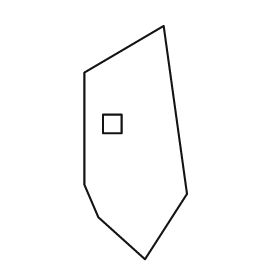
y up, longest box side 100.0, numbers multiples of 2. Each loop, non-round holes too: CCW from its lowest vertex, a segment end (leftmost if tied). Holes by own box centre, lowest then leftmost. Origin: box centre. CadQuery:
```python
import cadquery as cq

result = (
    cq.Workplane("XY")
    .moveTo(4.0, -50.0)
    .lineTo(22.0, -22.0)
    .lineTo(12.0, 50.0)
    .lineTo(-22.0, 30.0)
    .lineTo(-22.0, -18.0)
    .lineTo(-16.0, -32.0)
    .close()
    .moveTo(-14.0, 4.0)
    .lineTo(-6.0, 4.0)
    .lineTo(-6.0, 12.0)
    .lineTo(-14.0, 12.0)
    .close()
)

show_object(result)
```